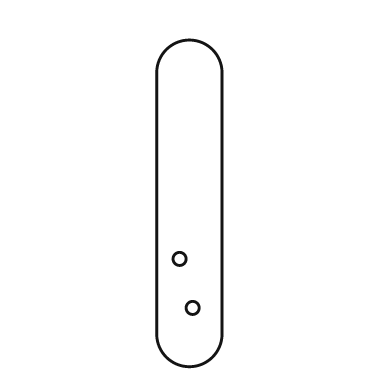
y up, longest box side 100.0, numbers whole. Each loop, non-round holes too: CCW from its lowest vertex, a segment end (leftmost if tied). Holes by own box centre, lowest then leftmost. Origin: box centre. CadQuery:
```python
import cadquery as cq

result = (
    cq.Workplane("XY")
    .moveTo(-10.0, -40.0)
    .threePointArc((0.0, -50.0), (10.0, -40.0))
    .lineTo(10.0, 40.0)
    .threePointArc((0.0, 50.0), (-10.0, 40.0))
    .close()
    .moveTo(1.0, -32.0)
    .circle(2.0)
    .moveTo(-3.0, -17.0)
    .circle(2.0)
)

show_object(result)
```